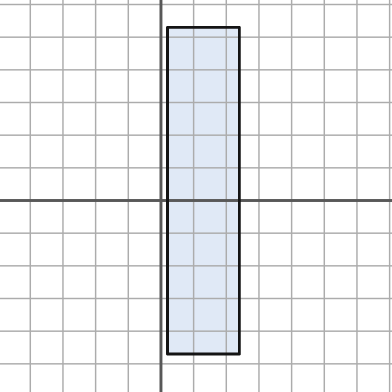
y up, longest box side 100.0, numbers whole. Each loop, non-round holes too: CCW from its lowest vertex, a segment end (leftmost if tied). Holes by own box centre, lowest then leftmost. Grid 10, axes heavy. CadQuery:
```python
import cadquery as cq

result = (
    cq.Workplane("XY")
    .moveTo(2.0, -47.0)
    .lineTo(24.0, -47.0)
    .lineTo(24.0, 53.0)
    .lineTo(2.0, 53.0)
    .close()
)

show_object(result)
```